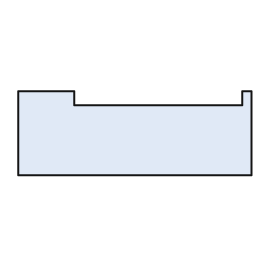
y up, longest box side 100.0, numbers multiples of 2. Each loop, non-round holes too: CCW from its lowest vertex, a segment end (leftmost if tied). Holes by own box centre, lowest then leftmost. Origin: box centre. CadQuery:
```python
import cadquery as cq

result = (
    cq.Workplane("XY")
    .moveTo(-50.0, -18.0)
    .lineTo(50.0, -18.0)
    .lineTo(50.0, 18.0)
    .lineTo(46.0, 18.0)
    .lineTo(46.0, 12.0)
    .lineTo(-26.0, 12.0)
    .lineTo(-26.0, 18.0)
    .lineTo(-50.0, 18.0)
    .close()
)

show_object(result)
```